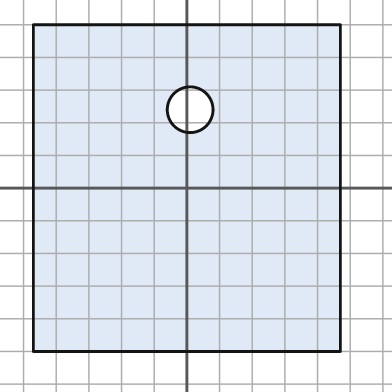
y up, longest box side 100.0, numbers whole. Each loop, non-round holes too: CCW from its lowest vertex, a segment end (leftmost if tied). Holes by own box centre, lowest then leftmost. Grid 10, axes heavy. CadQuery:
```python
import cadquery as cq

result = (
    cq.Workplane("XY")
    .moveTo(-47.0, -50.0)
    .lineTo(47.0, -50.0)
    .lineTo(47.0, 50.0)
    .lineTo(-47.0, 50.0)
    .close()
    .moveTo(1.0, 24.0)
    .circle(7.0)
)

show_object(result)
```